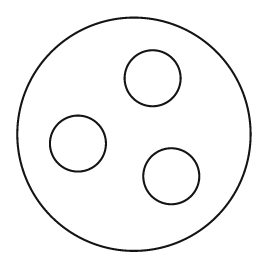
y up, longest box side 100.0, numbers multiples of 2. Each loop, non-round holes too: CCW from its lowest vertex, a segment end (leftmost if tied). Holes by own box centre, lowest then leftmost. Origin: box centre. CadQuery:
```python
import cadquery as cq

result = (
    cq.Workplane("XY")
    .moveTo(0.0, 0.0)
    .circle(50.0)
    .moveTo(16.0, -18.0)
    .circle(12.0)
    .moveTo(-24.0, -4.0)
    .circle(12.0)
    .moveTo(8.0, 24.0)
    .circle(12.0)
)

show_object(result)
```